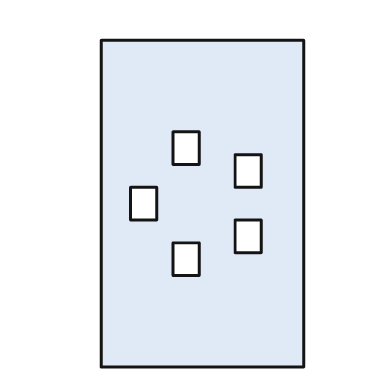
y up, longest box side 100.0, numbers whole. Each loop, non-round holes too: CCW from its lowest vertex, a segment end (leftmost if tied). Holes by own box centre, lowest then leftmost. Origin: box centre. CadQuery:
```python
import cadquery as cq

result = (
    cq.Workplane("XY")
    .moveTo(-31.0, -50.0)
    .lineTo(31.0, -50.0)
    .lineTo(31.0, 50.0)
    .lineTo(-31.0, 50.0)
    .close()
    .moveTo(-9.0, -22.0)
    .lineTo(-1.0, -22.0)
    .lineTo(-1.0, -12.0)
    .lineTo(-9.0, -12.0)
    .close()
    .moveTo(10.0, -15.0)
    .lineTo(18.0, -15.0)
    .lineTo(18.0, -5.0)
    .lineTo(10.0, -5.0)
    .close()
    .moveTo(-22.0, -5.0)
    .lineTo(-14.0, -5.0)
    .lineTo(-14.0, 5.0)
    .lineTo(-22.0, 5.0)
    .close()
    .moveTo(10.0, 5.0)
    .lineTo(18.0, 5.0)
    .lineTo(18.0, 15.0)
    .lineTo(10.0, 15.0)
    .close()
    .moveTo(-9.0, 12.0)
    .lineTo(-1.0, 12.0)
    .lineTo(-1.0, 22.0)
    .lineTo(-9.0, 22.0)
    .close()
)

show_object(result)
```